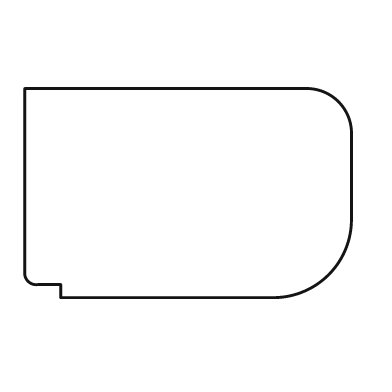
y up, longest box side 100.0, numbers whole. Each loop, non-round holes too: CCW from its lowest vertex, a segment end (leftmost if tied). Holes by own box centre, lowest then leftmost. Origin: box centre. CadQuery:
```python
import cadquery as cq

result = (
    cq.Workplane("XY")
    .moveTo(-39.0, -32.0)
    .lineTo(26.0, -32.0)
    .threePointArc((43.0, -25.0), (50.0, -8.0))
    .lineTo(50.0, 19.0)
    .threePointArc((46.0, 28.0), (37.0, 32.0))
    .lineTo(-50.0, 32.0)
    .lineTo(-50.0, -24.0)
    .threePointArc((-49.0, -27.0), (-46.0, -28.0))
    .lineTo(-39.0, -28.0)
    .close()
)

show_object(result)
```